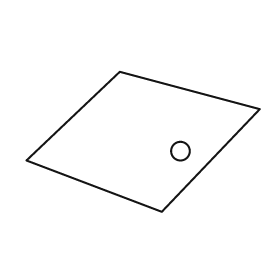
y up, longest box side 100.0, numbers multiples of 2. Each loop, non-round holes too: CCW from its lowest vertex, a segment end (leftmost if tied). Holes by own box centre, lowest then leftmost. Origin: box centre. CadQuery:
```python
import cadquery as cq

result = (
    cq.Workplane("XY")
    .moveTo(8.0, -30.0)
    .lineTo(50.0, 14.0)
    .lineTo(-10.0, 30.0)
    .lineTo(-50.0, -8.0)
    .close()
    .moveTo(16.0, -4.0)
    .circle(4.0)
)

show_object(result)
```